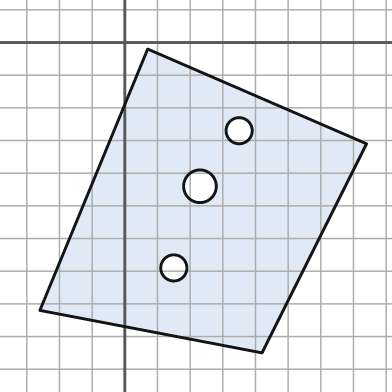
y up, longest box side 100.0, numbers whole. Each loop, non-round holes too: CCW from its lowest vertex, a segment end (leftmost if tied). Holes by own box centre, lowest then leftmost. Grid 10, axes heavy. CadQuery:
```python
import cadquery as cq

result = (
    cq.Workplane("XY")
    .moveTo(42.0, -95.0)
    .lineTo(74.0, -31.0)
    .lineTo(7.0, -2.0)
    .lineTo(-26.0, -82.0)
    .close()
    .moveTo(15.0, -69.0)
    .circle(4.0)
    .moveTo(23.0, -44.0)
    .circle(5.0)
    .moveTo(35.0, -27.0)
    .circle(4.0)
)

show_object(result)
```